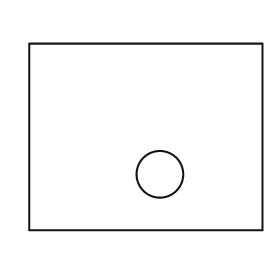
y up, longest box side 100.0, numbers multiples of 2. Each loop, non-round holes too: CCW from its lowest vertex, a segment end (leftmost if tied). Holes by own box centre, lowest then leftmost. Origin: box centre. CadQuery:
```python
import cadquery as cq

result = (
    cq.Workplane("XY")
    .moveTo(-50.0, -40.0)
    .lineTo(50.0, -40.0)
    .lineTo(50.0, 40.0)
    .lineTo(-50.0, 40.0)
    .close()
    .moveTo(6.0, -16.0)
    .circle(10.0)
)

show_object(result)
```